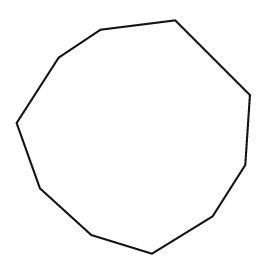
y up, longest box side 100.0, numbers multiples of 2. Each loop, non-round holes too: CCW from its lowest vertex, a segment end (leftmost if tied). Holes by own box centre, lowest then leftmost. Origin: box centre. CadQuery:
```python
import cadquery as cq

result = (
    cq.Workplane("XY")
    .moveTo(8.0, -50.0)
    .lineTo(34.0, -34.0)
    .lineTo(48.0, -12.0)
    .lineTo(50.0, 18.0)
    .lineTo(18.0, 50.0)
    .lineTo(-14.0, 46.0)
    .lineTo(-32.0, 34.0)
    .lineTo(-50.0, 6.0)
    .lineTo(-40.0, -22.0)
    .lineTo(-18.0, -42.0)
    .close()
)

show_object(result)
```